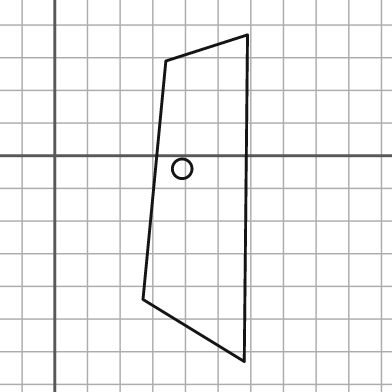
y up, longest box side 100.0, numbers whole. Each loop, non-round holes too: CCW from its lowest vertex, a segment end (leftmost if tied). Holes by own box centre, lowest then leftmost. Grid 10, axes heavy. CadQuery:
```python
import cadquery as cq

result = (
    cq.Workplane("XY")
    .moveTo(58.0, -63.0)
    .lineTo(59.0, 37.0)
    .lineTo(34.0, 29.0)
    .lineTo(27.0, -44.0)
    .close()
    .moveTo(39.0, -4.0)
    .circle(3.0)
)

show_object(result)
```